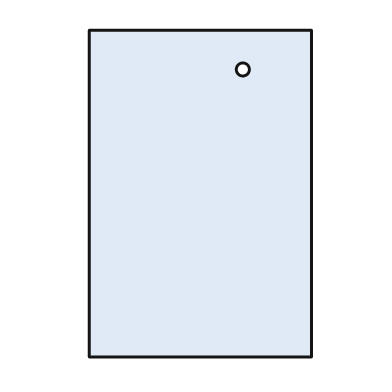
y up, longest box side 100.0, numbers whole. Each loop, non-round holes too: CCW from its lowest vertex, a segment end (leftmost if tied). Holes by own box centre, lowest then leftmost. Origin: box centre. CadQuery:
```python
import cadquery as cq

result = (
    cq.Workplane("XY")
    .moveTo(-34.0, -50.0)
    .lineTo(34.0, -50.0)
    .lineTo(34.0, 50.0)
    .lineTo(-34.0, 50.0)
    .close()
    .moveTo(13.0, 38.0)
    .circle(2.0)
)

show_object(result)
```